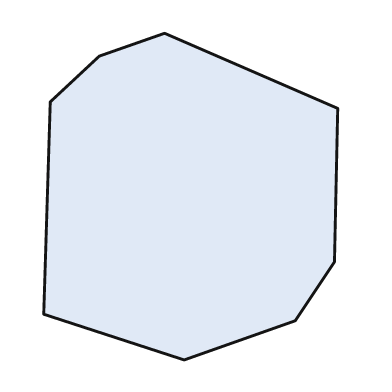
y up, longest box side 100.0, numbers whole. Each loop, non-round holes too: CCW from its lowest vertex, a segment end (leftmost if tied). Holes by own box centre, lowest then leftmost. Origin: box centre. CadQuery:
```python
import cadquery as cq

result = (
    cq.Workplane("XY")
    .moveTo(-2.0, -50.0)
    .lineTo(32.0, -38.0)
    .lineTo(44.0, -20.0)
    .lineTo(45.0, 27.0)
    .lineTo(-8.0, 50.0)
    .lineTo(-28.0, 43.0)
    .lineTo(-43.0, 29.0)
    .lineTo(-45.0, -36.0)
    .close()
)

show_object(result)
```